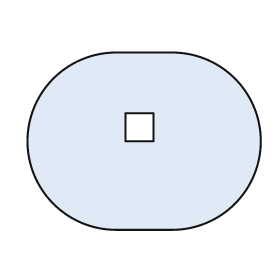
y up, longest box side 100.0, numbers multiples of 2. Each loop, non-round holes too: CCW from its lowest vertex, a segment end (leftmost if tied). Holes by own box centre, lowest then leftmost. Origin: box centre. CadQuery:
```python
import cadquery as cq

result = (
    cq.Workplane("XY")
    .moveTo(-12.0, -38.0)
    .lineTo(12.0, -38.0)
    .threePointArc((50.0, 0.0), (12.0, 38.0))
    .lineTo(-12.0, 38.0)
    .threePointArc((-50.0, 0.0), (-12.0, -38.0))
    .close()
    .moveTo(-8.0, 0.0)
    .lineTo(4.0, 0.0)
    .lineTo(4.0, 12.0)
    .lineTo(-8.0, 12.0)
    .close()
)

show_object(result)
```